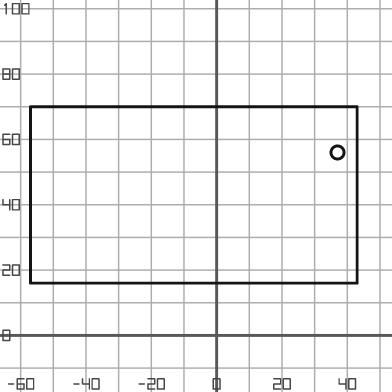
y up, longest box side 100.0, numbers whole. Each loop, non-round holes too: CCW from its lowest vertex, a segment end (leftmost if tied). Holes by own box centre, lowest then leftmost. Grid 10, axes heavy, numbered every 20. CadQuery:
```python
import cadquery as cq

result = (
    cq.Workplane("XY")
    .moveTo(-57.0, 16.0)
    .lineTo(43.0, 16.0)
    .lineTo(43.0, 70.0)
    .lineTo(-57.0, 70.0)
    .close()
    .moveTo(37.0, 56.0)
    .circle(2.0)
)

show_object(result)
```